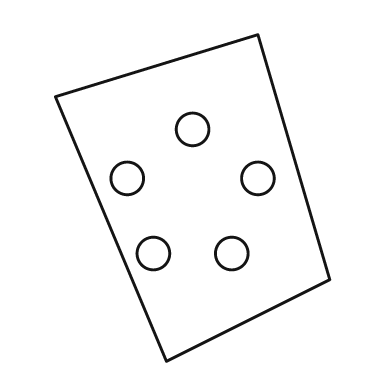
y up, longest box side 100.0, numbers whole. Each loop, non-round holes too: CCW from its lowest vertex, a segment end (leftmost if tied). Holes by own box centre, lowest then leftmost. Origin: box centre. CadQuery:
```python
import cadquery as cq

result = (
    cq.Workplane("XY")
    .moveTo(-8.0, -50.0)
    .lineTo(42.0, -25.0)
    .lineTo(20.0, 50.0)
    .lineTo(-42.0, 31.0)
    .close()
    .moveTo(-12.0, -17.0)
    .circle(5.0)
    .moveTo(12.0, -17.0)
    .circle(5.0)
    .moveTo(-20.0, 6.0)
    .circle(5.0)
    .moveTo(20.0, 6.0)
    .circle(5.0)
    .moveTo(0.0, 21.0)
    .circle(5.0)
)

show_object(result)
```